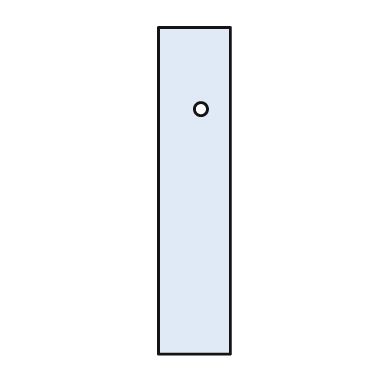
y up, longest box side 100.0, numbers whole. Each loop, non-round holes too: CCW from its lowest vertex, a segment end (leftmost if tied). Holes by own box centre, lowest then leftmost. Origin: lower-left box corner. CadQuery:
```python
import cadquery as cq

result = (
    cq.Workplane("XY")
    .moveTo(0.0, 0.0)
    .lineTo(22.0, 0.0)
    .lineTo(22.0, 100.0)
    .lineTo(0.0, 100.0)
    .close()
    .moveTo(13.0, 75.0)
    .circle(2.0)
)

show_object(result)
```